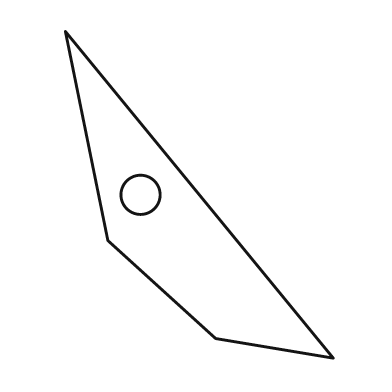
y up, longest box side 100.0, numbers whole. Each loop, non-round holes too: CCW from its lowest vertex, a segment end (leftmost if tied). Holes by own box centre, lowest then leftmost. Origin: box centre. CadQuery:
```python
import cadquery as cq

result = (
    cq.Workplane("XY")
    .moveTo(41.0, -50.0)
    .lineTo(-41.0, 50.0)
    .lineTo(-28.0, -14.0)
    .lineTo(5.0, -44.0)
    .close()
    .moveTo(-18.0, 0.0)
    .circle(6.0)
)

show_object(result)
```